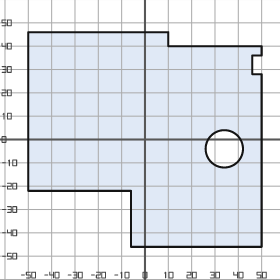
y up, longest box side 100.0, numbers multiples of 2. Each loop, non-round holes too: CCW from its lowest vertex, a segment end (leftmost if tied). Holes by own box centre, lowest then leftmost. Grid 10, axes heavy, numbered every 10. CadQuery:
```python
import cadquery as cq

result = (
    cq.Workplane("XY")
    .moveTo(-6.0, -46.0)
    .lineTo(50.0, -46.0)
    .lineTo(50.0, 28.0)
    .lineTo(46.0, 28.0)
    .lineTo(46.0, 36.0)
    .lineTo(50.0, 36.0)
    .lineTo(50.0, 40.0)
    .lineTo(10.0, 40.0)
    .lineTo(10.0, 46.0)
    .lineTo(-50.0, 46.0)
    .lineTo(-50.0, -22.0)
    .lineTo(-6.0, -22.0)
    .close()
    .moveTo(34.0, -4.0)
    .circle(8.0)
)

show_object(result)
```